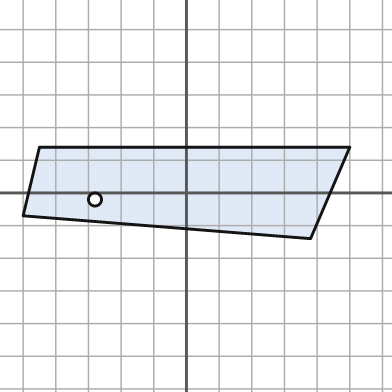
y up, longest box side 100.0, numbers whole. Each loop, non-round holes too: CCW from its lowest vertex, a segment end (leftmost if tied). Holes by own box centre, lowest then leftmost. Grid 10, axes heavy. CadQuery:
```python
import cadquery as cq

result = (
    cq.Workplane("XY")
    .moveTo(38.0, -14.0)
    .lineTo(50.0, 14.0)
    .lineTo(-45.0, 14.0)
    .lineTo(-50.0, -7.0)
    .close()
    .moveTo(-28.0, -2.0)
    .circle(2.0)
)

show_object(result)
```